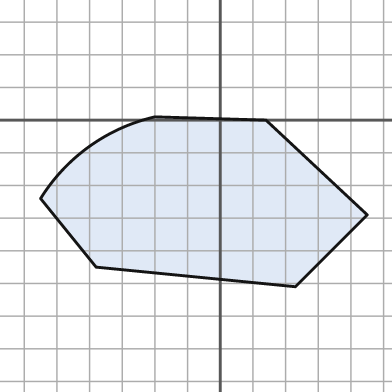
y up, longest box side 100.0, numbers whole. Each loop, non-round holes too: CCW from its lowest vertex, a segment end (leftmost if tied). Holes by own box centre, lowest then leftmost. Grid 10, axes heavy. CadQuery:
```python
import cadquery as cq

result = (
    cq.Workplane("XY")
    .moveTo(23.0, -51.0)
    .lineTo(45.0, -29.0)
    .lineTo(14.0, 0.0)
    .lineTo(-20.0, 1.0)
    .threePointArc((-40.0, -8.0), (-55.0, -24.0))
    .lineTo(-38.0, -45.0)
    .close()
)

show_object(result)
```